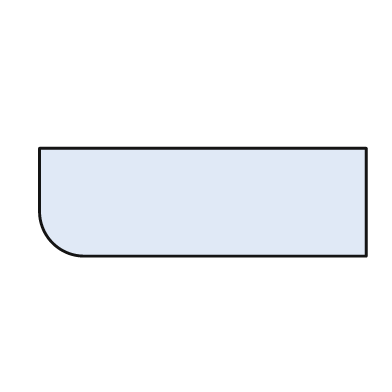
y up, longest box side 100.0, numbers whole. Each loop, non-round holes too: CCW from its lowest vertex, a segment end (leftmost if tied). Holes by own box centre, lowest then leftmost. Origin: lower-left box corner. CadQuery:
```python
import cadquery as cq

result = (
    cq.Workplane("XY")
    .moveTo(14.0, 0.0)
    .lineTo(100.0, 0.0)
    .lineTo(100.0, 33.0)
    .lineTo(0.0, 33.0)
    .lineTo(0.0, 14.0)
    .threePointArc((4.0, 4.0), (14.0, 0.0))
    .close()
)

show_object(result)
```